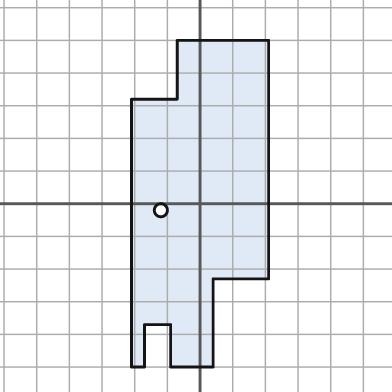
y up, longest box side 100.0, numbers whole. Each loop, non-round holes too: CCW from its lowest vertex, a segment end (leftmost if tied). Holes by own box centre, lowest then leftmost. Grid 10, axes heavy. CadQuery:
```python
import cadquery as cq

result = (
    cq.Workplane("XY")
    .moveTo(-21.0, -50.0)
    .lineTo(-17.0, -50.0)
    .lineTo(-17.0, -37.0)
    .lineTo(-9.0, -37.0)
    .lineTo(-9.0, -50.0)
    .lineTo(4.0, -50.0)
    .lineTo(4.0, -23.0)
    .lineTo(21.0, -23.0)
    .lineTo(21.0, 50.0)
    .lineTo(-7.0, 50.0)
    .lineTo(-7.0, 32.0)
    .lineTo(-21.0, 32.0)
    .close()
    .moveTo(-12.0, -2.0)
    .circle(2.0)
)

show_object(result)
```